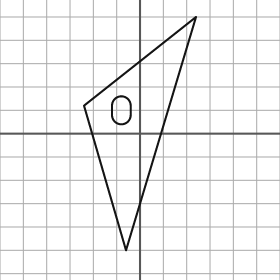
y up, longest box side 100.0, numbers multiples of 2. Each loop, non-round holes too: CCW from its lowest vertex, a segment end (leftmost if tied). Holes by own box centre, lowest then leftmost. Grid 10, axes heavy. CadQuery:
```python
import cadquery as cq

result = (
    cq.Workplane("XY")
    .moveTo(-6.0, -50.0)
    .lineTo(24.0, 50.0)
    .lineTo(-24.0, 12.0)
    .close()
    .moveTo(-12.0, 8.0)
    .threePointArc((-8.0, 4.0), (-4.0, 8.0))
    .lineTo(-4.0, 12.0)
    .threePointArc((-8.0, 16.0), (-12.0, 12.0))
    .close()
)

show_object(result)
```